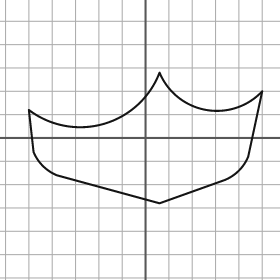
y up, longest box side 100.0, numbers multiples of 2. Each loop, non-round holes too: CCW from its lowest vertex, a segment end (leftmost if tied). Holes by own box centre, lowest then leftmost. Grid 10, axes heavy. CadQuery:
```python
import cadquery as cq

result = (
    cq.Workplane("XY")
    .moveTo(6.0, -28.0)
    .lineTo(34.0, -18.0)
    .threePointArc((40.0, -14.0), (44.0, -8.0))
    .lineTo(50.0, 20.0)
    .threePointArc((26.0, 12.0), (6.0, 28.0))
    .threePointArc((-18.0, 6.0), (-50.0, 12.0))
    .lineTo(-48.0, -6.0)
    .threePointArc((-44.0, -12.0), (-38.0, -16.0))
    .close()
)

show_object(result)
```